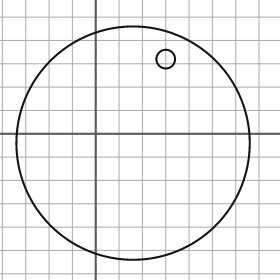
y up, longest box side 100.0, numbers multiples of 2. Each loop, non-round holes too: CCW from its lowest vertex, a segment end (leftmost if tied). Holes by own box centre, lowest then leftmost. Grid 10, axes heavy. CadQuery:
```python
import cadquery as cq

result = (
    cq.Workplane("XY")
    .moveTo(16.0, -4.0)
    .circle(50.0)
    .moveTo(30.0, 32.0)
    .circle(4.0)
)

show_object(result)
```